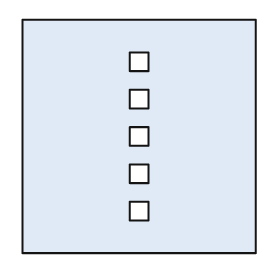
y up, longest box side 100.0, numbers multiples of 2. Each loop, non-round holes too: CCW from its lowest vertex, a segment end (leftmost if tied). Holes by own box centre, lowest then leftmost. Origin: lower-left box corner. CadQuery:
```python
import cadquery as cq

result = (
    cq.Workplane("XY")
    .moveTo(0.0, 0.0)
    .lineTo(100.0, 0.0)
    .lineTo(100.0, 100.0)
    .lineTo(0.0, 100.0)
    .close()
    .moveTo(46.0, 14.0)
    .lineTo(54.0, 14.0)
    .lineTo(54.0, 22.0)
    .lineTo(46.0, 22.0)
    .close()
    .moveTo(46.0, 30.0)
    .lineTo(54.0, 30.0)
    .lineTo(54.0, 38.0)
    .lineTo(46.0, 38.0)
    .close()
    .moveTo(46.0, 46.0)
    .lineTo(54.0, 46.0)
    .lineTo(54.0, 54.0)
    .lineTo(46.0, 54.0)
    .close()
    .moveTo(46.0, 62.0)
    .lineTo(54.0, 62.0)
    .lineTo(54.0, 70.0)
    .lineTo(46.0, 70.0)
    .close()
    .moveTo(46.0, 78.0)
    .lineTo(54.0, 78.0)
    .lineTo(54.0, 86.0)
    .lineTo(46.0, 86.0)
    .close()
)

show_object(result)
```